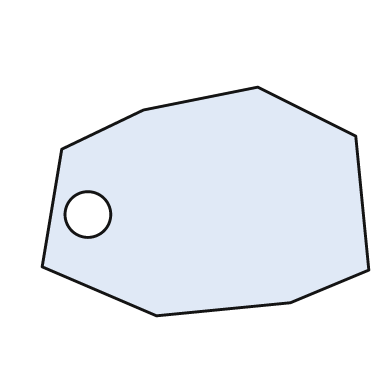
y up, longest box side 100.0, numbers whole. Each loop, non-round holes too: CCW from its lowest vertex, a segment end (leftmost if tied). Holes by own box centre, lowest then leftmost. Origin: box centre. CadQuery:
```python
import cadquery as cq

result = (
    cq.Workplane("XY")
    .moveTo(-15.0, -35.0)
    .lineTo(26.0, -31.0)
    .lineTo(50.0, -21.0)
    .lineTo(46.0, 20.0)
    .lineTo(16.0, 35.0)
    .lineTo(-19.0, 28.0)
    .lineTo(-44.0, 16.0)
    .lineTo(-50.0, -20.0)
    .close()
    .moveTo(-36.0, -4.0)
    .circle(7.0)
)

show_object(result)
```